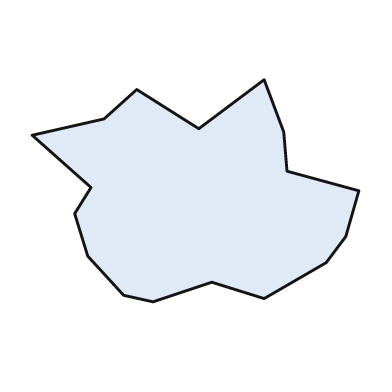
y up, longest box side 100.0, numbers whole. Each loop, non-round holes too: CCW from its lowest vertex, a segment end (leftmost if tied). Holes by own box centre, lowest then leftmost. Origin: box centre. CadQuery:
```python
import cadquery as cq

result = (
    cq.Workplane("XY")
    .moveTo(-13.0, -34.0)
    .lineTo(5.0, -28.0)
    .lineTo(21.0, -33.0)
    .lineTo(40.0, -22.0)
    .lineTo(46.0, -14.0)
    .lineTo(50.0, 0.0)
    .lineTo(28.0, 6.0)
    .lineTo(27.0, 18.0)
    .lineTo(21.0, 34.0)
    .lineTo(1.0, 19.0)
    .lineTo(-18.0, 31.0)
    .lineTo(-28.0, 22.0)
    .lineTo(-50.0, 17.0)
    .lineTo(-32.0, 1.0)
    .lineTo(-37.0, -7.0)
    .lineTo(-33.0, -20.0)
    .lineTo(-22.0, -32.0)
    .close()
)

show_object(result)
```